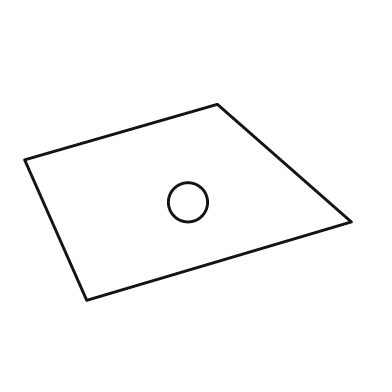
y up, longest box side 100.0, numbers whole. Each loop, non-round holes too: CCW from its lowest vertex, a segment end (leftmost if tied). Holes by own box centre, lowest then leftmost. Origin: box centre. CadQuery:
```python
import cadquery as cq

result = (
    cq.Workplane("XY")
    .moveTo(-31.0, -30.0)
    .lineTo(50.0, -6.0)
    .lineTo(9.0, 30.0)
    .lineTo(-50.0, 13.0)
    .close()
    .moveTo(0.0, 0.0)
    .circle(6.0)
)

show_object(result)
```